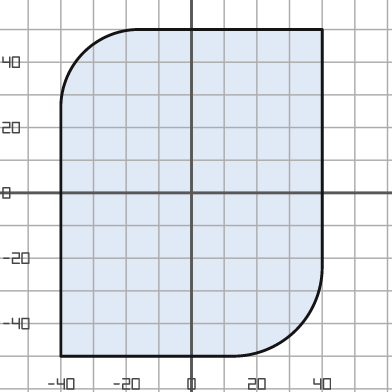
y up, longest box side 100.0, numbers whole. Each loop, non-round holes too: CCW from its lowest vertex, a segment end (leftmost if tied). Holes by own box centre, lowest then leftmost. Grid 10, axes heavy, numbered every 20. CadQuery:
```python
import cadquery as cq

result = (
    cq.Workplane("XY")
    .moveTo(-40.0, -50.0)
    .lineTo(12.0, -50.0)
    .threePointArc((32.0, -42.0), (40.0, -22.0))
    .lineTo(40.0, 50.0)
    .lineTo(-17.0, 50.0)
    .threePointArc((-33.0, 43.0), (-40.0, 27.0))
    .close()
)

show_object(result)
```